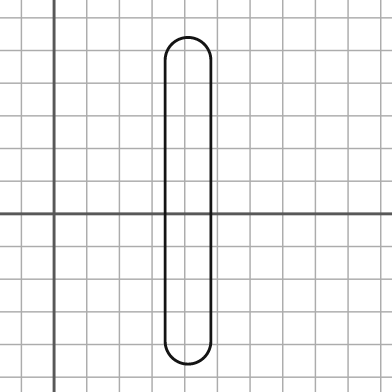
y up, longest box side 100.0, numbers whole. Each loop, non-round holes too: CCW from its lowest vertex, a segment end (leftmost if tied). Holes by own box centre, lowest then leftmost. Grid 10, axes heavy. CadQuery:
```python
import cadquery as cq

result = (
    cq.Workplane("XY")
    .moveTo(34.0, -39.0)
    .threePointArc((41.0, -46.0), (48.0, -39.0))
    .lineTo(48.0, 47.0)
    .threePointArc((41.0, 54.0), (34.0, 47.0))
    .close()
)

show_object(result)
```